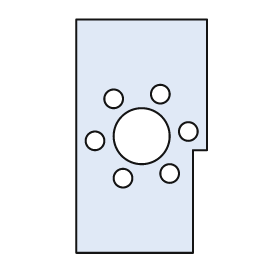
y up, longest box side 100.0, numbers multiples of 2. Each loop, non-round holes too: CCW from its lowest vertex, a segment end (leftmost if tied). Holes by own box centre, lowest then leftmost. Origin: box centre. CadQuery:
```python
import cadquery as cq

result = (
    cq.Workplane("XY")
    .moveTo(-28.0, -50.0)
    .lineTo(22.0, -50.0)
    .lineTo(22.0, -6.0)
    .lineTo(28.0, -6.0)
    .lineTo(28.0, 50.0)
    .lineTo(-28.0, 50.0)
    .close()
    .moveTo(-8.0, -18.0)
    .circle(4.0)
    .moveTo(12.0, -16.0)
    .circle(4.0)
    .moveTo(-20.0, -2.0)
    .circle(4.0)
    .moveTo(0.0, 0.0)
    .circle(12.0)
    .moveTo(20.0, 2.0)
    .circle(4.0)
    .moveTo(-12.0, 16.0)
    .circle(4.0)
    .moveTo(8.0, 18.0)
    .circle(4.0)
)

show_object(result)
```